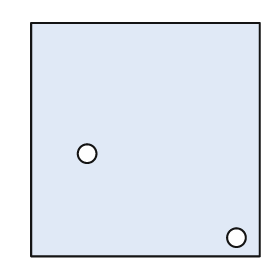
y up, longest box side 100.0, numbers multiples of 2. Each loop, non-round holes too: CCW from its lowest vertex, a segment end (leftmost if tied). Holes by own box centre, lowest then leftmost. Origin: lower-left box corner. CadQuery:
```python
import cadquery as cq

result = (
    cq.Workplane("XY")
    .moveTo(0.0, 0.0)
    .lineTo(98.0, 0.0)
    .lineTo(98.0, 100.0)
    .lineTo(0.0, 100.0)
    .close()
    .moveTo(88.0, 8.0)
    .circle(4.0)
    .moveTo(24.0, 44.0)
    .circle(4.0)
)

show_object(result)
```